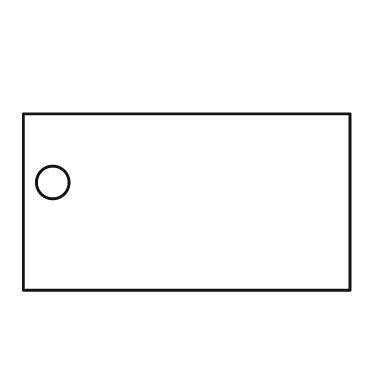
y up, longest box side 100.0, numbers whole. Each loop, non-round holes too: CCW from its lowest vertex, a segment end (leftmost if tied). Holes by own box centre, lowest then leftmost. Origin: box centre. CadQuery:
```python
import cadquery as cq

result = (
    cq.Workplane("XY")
    .moveTo(-50.0, -27.0)
    .lineTo(50.0, -27.0)
    .lineTo(50.0, 27.0)
    .lineTo(-50.0, 27.0)
    .close()
    .moveTo(-41.0, 6.0)
    .circle(5.0)
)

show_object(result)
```